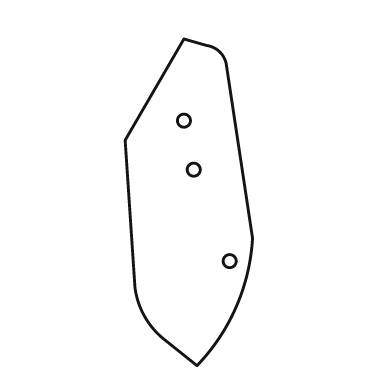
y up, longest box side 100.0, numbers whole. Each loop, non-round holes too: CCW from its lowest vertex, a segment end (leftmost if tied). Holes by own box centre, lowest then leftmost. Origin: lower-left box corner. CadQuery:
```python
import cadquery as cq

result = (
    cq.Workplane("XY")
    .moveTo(22.0, 0.0)
    .threePointArc((34.0, 18.0), (39.0, 39.0))
    .lineTo(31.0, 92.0)
    .threePointArc((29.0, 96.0), (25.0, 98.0))
    .lineTo(18.0, 100.0)
    .lineTo(0.0, 69.0)
    .lineTo(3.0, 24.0)
    .threePointArc((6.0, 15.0), (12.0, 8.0))
    .close()
    .moveTo(32.0, 32.0)
    .circle(2.0)
    .moveTo(21.0, 60.0)
    .circle(2.0)
    .moveTo(18.0, 75.0)
    .circle(2.0)
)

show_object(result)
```